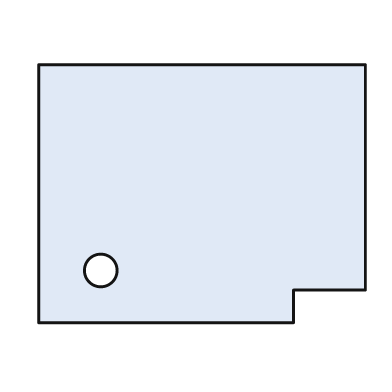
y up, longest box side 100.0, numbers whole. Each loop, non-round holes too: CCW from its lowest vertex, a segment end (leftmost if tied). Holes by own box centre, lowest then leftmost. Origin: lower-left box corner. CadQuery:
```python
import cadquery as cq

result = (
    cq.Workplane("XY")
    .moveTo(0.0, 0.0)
    .lineTo(78.0, 0.0)
    .lineTo(78.0, 10.0)
    .lineTo(100.0, 10.0)
    .lineTo(100.0, 79.0)
    .lineTo(0.0, 79.0)
    .close()
    .moveTo(19.0, 16.0)
    .circle(5.0)
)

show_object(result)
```